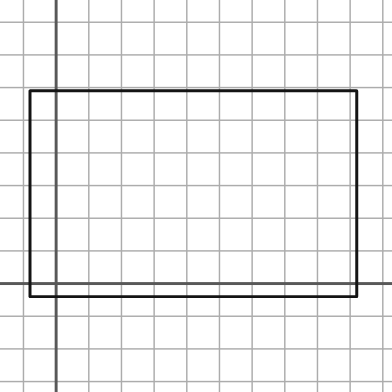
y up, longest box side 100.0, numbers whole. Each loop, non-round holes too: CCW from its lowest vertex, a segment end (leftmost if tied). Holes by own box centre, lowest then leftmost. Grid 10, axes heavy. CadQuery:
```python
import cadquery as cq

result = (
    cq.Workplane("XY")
    .moveTo(-8.0, -4.0)
    .lineTo(92.0, -4.0)
    .lineTo(92.0, 59.0)
    .lineTo(-8.0, 59.0)
    .close()
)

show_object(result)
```